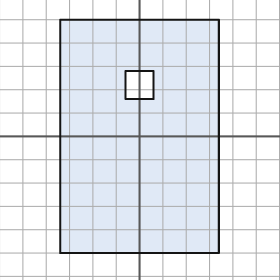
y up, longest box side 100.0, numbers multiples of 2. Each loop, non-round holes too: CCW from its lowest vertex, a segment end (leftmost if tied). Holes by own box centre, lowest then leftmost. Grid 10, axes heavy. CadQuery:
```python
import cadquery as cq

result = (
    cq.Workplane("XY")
    .moveTo(-34.0, -50.0)
    .lineTo(34.0, -50.0)
    .lineTo(34.0, 50.0)
    .lineTo(-34.0, 50.0)
    .close()
    .moveTo(-6.0, 16.0)
    .lineTo(6.0, 16.0)
    .lineTo(6.0, 28.0)
    .lineTo(-6.0, 28.0)
    .close()
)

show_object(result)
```